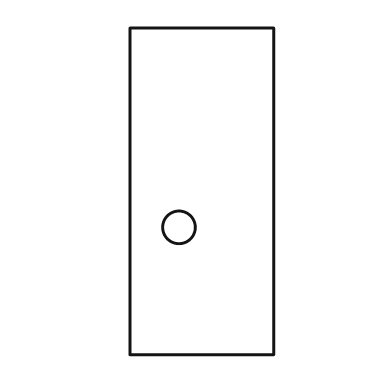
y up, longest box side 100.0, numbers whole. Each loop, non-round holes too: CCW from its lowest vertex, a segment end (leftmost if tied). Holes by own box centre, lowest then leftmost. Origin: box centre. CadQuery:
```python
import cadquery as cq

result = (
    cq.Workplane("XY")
    .moveTo(-22.0, -50.0)
    .lineTo(22.0, -50.0)
    .lineTo(22.0, 50.0)
    .lineTo(-22.0, 50.0)
    .close()
    .moveTo(-7.0, -11.0)
    .circle(5.0)
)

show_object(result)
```